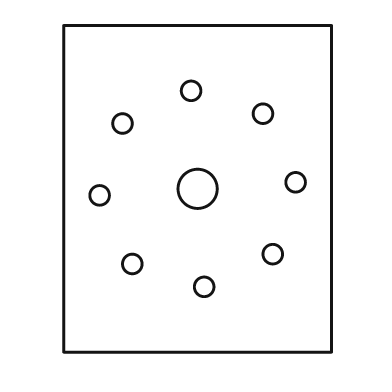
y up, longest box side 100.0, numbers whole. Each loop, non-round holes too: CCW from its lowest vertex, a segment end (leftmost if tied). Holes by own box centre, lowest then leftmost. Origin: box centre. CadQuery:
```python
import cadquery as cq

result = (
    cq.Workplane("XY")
    .moveTo(-41.0, -50.0)
    .lineTo(41.0, -50.0)
    .lineTo(41.0, 50.0)
    .lineTo(-41.0, 50.0)
    .close()
    .moveTo(2.0, -30.0)
    .circle(3.0)
    .moveTo(-20.0, -23.0)
    .circle(3.0)
    .moveTo(23.0, -20.0)
    .circle(3.0)
    .moveTo(-30.0, -2.0)
    .circle(3.0)
    .moveTo(0.0, 0.0)
    .circle(6.0)
    .moveTo(30.0, 2.0)
    .circle(3.0)
    .moveTo(-23.0, 20.0)
    .circle(3.0)
    .moveTo(20.0, 23.0)
    .circle(3.0)
    .moveTo(-2.0, 30.0)
    .circle(3.0)
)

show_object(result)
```